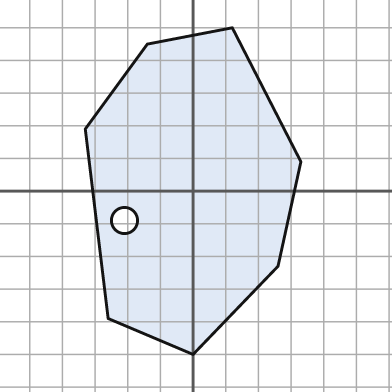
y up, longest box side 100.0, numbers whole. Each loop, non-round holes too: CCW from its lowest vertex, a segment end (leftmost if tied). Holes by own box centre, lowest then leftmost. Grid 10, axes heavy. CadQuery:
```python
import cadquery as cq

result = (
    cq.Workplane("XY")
    .moveTo(0.0, -50.0)
    .lineTo(26.0, -23.0)
    .lineTo(33.0, 9.0)
    .lineTo(12.0, 50.0)
    .lineTo(-14.0, 45.0)
    .lineTo(-33.0, 19.0)
    .lineTo(-26.0, -39.0)
    .close()
    .moveTo(-21.0, -9.0)
    .circle(4.0)
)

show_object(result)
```